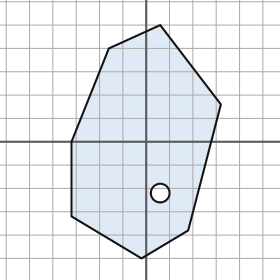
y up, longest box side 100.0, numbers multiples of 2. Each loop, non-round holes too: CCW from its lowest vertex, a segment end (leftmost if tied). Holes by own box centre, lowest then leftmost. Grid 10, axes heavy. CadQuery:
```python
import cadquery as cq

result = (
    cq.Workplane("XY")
    .moveTo(-2.0, -50.0)
    .lineTo(18.0, -38.0)
    .lineTo(32.0, 16.0)
    .lineTo(6.0, 50.0)
    .lineTo(-16.0, 40.0)
    .lineTo(-32.0, 0.0)
    .lineTo(-32.0, -32.0)
    .close()
    .moveTo(6.0, -22.0)
    .circle(4.0)
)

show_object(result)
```